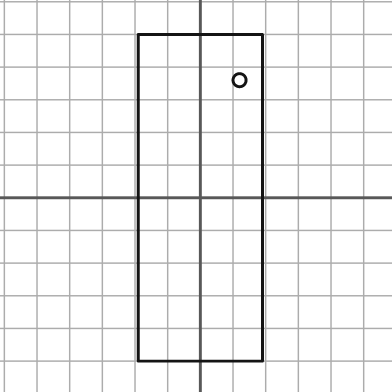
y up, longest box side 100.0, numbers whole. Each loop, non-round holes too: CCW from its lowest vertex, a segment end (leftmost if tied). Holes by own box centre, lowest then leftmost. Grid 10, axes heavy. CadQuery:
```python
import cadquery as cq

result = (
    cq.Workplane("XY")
    .moveTo(-19.0, -50.0)
    .lineTo(19.0, -50.0)
    .lineTo(19.0, 50.0)
    .lineTo(-19.0, 50.0)
    .close()
    .moveTo(12.0, 36.0)
    .circle(2.0)
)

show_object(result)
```